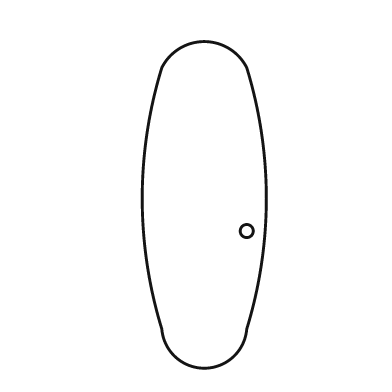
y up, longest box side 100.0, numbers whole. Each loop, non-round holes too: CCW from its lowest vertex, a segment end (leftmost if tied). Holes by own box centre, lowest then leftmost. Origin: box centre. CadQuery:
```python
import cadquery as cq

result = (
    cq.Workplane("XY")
    .moveTo(-13.0, -38.0)
    .threePointArc((0.0, -50.0), (13.0, -38.0))
    .threePointArc((19.0, 2.0), (13.0, 42.0))
    .threePointArc((0.0, 50.0), (-13.0, 42.0))
    .threePointArc((-19.0, 2.0), (-13.0, -38.0))
    .close()
    .moveTo(13.0, -8.0)
    .circle(2.0)
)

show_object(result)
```